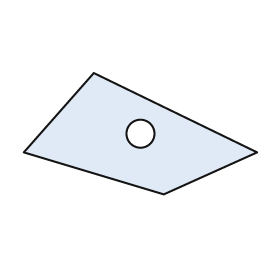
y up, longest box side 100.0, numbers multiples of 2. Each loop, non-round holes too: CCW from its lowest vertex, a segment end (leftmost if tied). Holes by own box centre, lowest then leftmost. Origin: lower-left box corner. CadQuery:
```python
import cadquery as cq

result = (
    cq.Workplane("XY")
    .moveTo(60.0, 0.0)
    .lineTo(100.0, 18.0)
    .lineTo(30.0, 52.0)
    .lineTo(0.0, 18.0)
    .close()
    .moveTo(50.0, 26.0)
    .circle(6.0)
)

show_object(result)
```